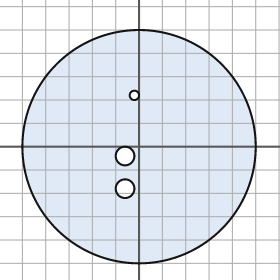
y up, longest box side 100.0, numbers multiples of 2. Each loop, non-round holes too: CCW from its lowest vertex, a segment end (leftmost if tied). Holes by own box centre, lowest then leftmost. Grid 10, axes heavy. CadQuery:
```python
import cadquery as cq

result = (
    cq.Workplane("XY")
    .moveTo(0.0, 0.0)
    .circle(50.0)
    .moveTo(-6.0, -18.0)
    .circle(4.0)
    .moveTo(-6.0, -4.0)
    .circle(4.0)
    .moveTo(-2.0, 22.0)
    .circle(2.0)
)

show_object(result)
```